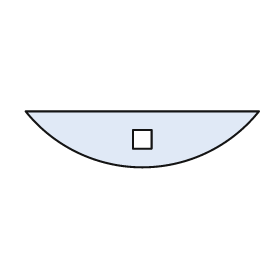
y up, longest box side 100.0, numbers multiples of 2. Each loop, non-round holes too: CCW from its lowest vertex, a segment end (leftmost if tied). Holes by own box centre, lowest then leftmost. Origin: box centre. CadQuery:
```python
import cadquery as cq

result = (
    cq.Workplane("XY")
    .moveTo(-50.0, 12.0)
    .threePointArc((0.0, -12.0), (50.0, 12.0))
    .close()
    .moveTo(-4.0, -4.0)
    .lineTo(4.0, -4.0)
    .lineTo(4.0, 4.0)
    .lineTo(-4.0, 4.0)
    .close()
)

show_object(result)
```